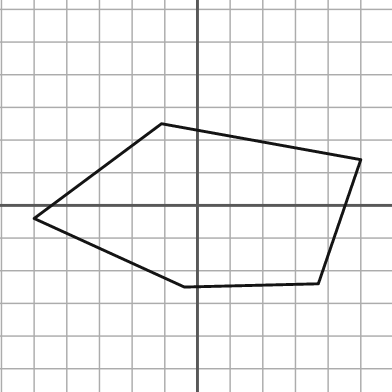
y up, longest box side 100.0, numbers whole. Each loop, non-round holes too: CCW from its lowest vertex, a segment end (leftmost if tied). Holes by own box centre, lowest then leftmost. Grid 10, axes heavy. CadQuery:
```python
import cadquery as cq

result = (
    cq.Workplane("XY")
    .moveTo(-4.0, -25.0)
    .lineTo(37.0, -24.0)
    .lineTo(50.0, 14.0)
    .lineTo(-11.0, 25.0)
    .lineTo(-50.0, -4.0)
    .close()
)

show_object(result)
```